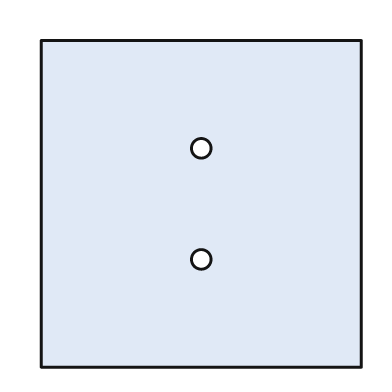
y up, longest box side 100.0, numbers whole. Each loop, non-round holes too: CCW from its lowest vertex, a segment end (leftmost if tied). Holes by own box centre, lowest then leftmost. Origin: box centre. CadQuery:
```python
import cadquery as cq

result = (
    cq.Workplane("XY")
    .moveTo(-49.0, -50.0)
    .lineTo(49.0, -50.0)
    .lineTo(49.0, 50.0)
    .lineTo(-49.0, 50.0)
    .close()
    .moveTo(0.0, -17.0)
    .circle(3.0)
    .moveTo(0.0, 17.0)
    .circle(3.0)
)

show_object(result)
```